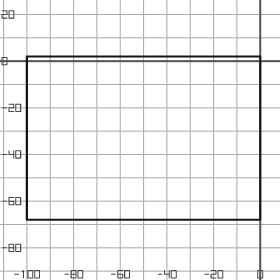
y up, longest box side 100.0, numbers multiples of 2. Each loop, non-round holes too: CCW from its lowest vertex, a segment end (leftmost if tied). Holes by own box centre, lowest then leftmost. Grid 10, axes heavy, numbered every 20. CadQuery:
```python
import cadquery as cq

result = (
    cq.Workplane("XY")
    .moveTo(-100.0, -68.0)
    .lineTo(0.0, -68.0)
    .lineTo(0.0, 2.0)
    .lineTo(-100.0, 2.0)
    .close()
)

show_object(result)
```